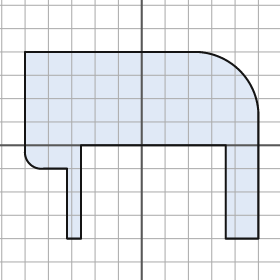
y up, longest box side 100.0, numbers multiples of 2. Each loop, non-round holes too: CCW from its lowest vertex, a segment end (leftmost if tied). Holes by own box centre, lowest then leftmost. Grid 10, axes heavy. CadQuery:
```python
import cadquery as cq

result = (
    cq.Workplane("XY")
    .moveTo(-32.0, -40.0)
    .lineTo(-26.0, -40.0)
    .lineTo(-26.0, 0.0)
    .lineTo(36.0, 0.0)
    .lineTo(36.0, -40.0)
    .lineTo(50.0, -40.0)
    .lineTo(50.0, 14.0)
    .threePointArc((42.0, 32.0), (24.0, 40.0))
    .lineTo(-50.0, 40.0)
    .lineTo(-50.0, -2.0)
    .threePointArc((-48.0, -8.0), (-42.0, -10.0))
    .lineTo(-32.0, -10.0)
    .close()
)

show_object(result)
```